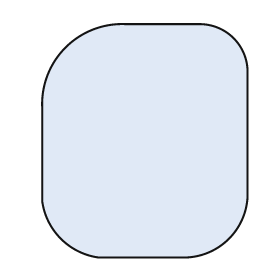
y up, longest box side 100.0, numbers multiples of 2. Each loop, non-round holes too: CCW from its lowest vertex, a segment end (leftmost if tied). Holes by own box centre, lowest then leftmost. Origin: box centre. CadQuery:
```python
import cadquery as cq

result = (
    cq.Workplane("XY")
    .moveTo(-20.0, -50.0)
    .lineTo(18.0, -50.0)
    .threePointArc((36.0, -42.0), (44.0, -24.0))
    .lineTo(44.0, 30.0)
    .threePointArc((38.0, 44.0), (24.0, 50.0))
    .lineTo(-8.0, 50.0)
    .threePointArc((-34.0, 40.0), (-44.0, 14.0))
    .lineTo(-44.0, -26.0)
    .threePointArc((-36.0, -42.0), (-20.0, -50.0))
    .close()
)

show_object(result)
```